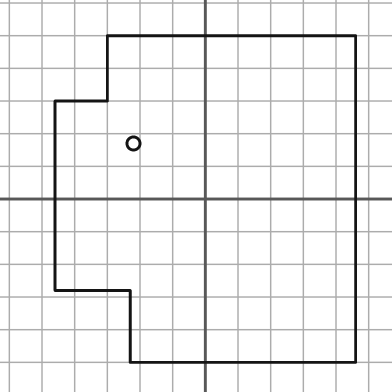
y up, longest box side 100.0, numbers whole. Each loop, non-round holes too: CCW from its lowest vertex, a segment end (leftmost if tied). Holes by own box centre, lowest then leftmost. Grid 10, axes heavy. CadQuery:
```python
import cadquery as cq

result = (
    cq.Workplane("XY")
    .moveTo(-23.0, -50.0)
    .lineTo(46.0, -50.0)
    .lineTo(46.0, 50.0)
    .lineTo(-30.0, 50.0)
    .lineTo(-30.0, 30.0)
    .lineTo(-46.0, 30.0)
    .lineTo(-46.0, -28.0)
    .lineTo(-23.0, -28.0)
    .close()
    .moveTo(-22.0, 17.0)
    .circle(2.0)
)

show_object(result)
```